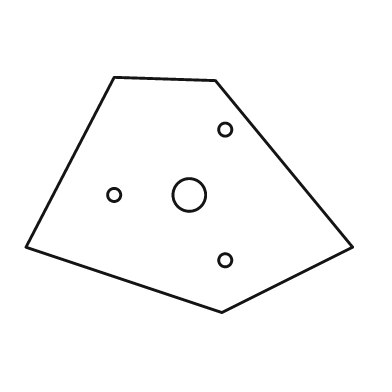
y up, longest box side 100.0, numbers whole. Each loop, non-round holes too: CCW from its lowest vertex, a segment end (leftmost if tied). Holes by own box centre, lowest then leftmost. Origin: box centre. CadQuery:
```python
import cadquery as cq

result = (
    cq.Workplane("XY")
    .moveTo(10.0, -36.0)
    .lineTo(50.0, -16.0)
    .lineTo(8.0, 35.0)
    .lineTo(-23.0, 36.0)
    .lineTo(-50.0, -16.0)
    .close()
    .moveTo(11.0, -20.0)
    .circle(2.0)
    .moveTo(-23.0, 0.0)
    .circle(2.0)
    .moveTo(0.0, 0.0)
    .circle(5.0)
    .moveTo(11.0, 20.0)
    .circle(2.0)
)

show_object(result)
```